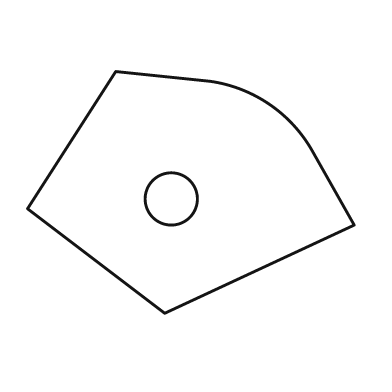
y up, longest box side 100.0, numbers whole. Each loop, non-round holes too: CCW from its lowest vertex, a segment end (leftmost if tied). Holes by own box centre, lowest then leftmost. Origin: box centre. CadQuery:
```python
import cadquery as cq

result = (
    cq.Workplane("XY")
    .moveTo(-8.0, -37.0)
    .lineTo(50.0, -10.0)
    .lineTo(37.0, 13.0)
    .threePointArc((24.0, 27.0), (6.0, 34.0))
    .lineTo(-23.0, 37.0)
    .lineTo(-50.0, -5.0)
    .close()
    .moveTo(-6.0, -2.0)
    .circle(8.0)
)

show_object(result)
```